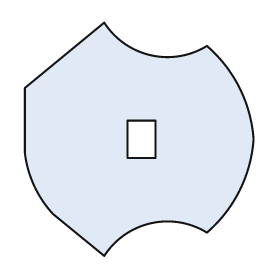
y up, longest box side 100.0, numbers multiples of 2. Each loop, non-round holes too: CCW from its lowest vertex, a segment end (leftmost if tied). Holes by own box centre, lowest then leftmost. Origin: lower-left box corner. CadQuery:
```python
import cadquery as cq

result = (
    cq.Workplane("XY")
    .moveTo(34.0, 0.0)
    .threePointArc((54.0, 14.0), (78.0, 10.0))
    .threePointArc((92.0, 28.0), (98.0, 50.0))
    .threePointArc((92.0, 72.0), (78.0, 90.0))
    .threePointArc((54.0, 86.0), (34.0, 100.0))
    .lineTo(0.0, 72.0)
    .lineTo(0.0, 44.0)
    .threePointArc((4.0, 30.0), (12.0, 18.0))
    .close()
    .moveTo(44.0, 42.0)
    .lineTo(56.0, 42.0)
    .lineTo(56.0, 58.0)
    .lineTo(44.0, 58.0)
    .close()
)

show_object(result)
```